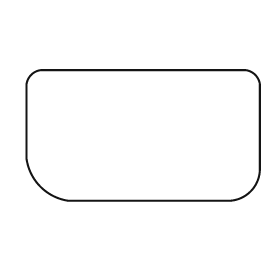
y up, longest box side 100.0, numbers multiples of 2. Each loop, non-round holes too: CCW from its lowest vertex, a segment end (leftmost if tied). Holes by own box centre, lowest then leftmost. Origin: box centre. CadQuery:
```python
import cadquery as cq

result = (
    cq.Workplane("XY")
    .moveTo(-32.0, -28.0)
    .lineTo(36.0, -28.0)
    .threePointArc((46.0, -24.0), (50.0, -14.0))
    .lineTo(50.0, 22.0)
    .threePointArc((48.0, 26.0), (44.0, 28.0))
    .lineTo(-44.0, 28.0)
    .threePointArc((-48.0, 26.0), (-50.0, 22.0))
    .lineTo(-50.0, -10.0)
    .threePointArc((-44.0, -22.0), (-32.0, -28.0))
    .close()
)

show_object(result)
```